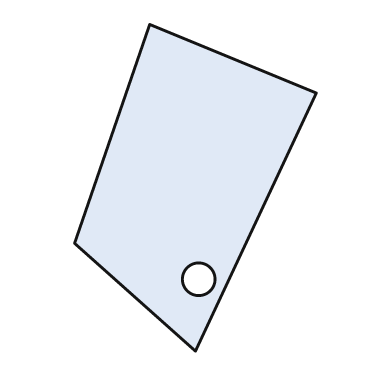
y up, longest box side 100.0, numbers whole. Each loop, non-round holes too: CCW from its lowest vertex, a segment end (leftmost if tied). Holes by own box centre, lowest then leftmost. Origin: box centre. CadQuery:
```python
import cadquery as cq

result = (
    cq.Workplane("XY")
    .moveTo(0.0, -50.0)
    .lineTo(37.0, 29.0)
    .lineTo(-14.0, 50.0)
    .lineTo(-37.0, -17.0)
    .close()
    .moveTo(1.0, -28.0)
    .circle(5.0)
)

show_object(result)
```